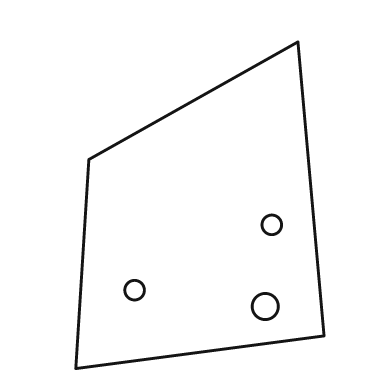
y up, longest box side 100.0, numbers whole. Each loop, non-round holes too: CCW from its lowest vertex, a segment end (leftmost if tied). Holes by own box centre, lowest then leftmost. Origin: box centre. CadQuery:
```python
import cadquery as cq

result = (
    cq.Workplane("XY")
    .moveTo(-38.0, -50.0)
    .lineTo(38.0, -40.0)
    .lineTo(30.0, 50.0)
    .lineTo(-34.0, 14.0)
    .close()
    .moveTo(20.0, -31.0)
    .circle(4.0)
    .moveTo(-20.0, -26.0)
    .circle(3.0)
    .moveTo(22.0, -6.0)
    .circle(3.0)
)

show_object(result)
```